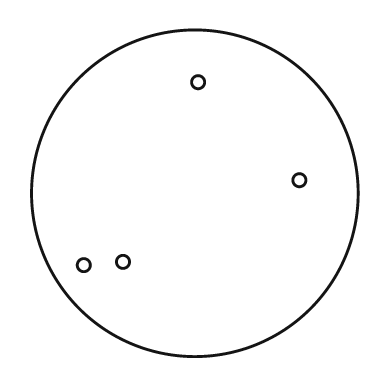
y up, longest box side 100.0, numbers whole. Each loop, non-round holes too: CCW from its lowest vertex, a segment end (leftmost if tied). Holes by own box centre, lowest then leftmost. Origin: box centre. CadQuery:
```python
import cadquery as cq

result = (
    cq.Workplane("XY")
    .moveTo(0.0, 0.0)
    .circle(50.0)
    .moveTo(-34.0, -22.0)
    .circle(2.0)
    .moveTo(-22.0, -21.0)
    .circle(2.0)
    .moveTo(32.0, 4.0)
    .circle(2.0)
    .moveTo(1.0, 34.0)
    .circle(2.0)
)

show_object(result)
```